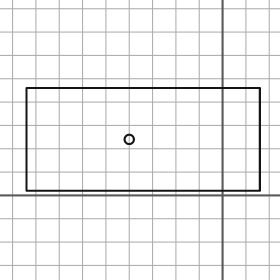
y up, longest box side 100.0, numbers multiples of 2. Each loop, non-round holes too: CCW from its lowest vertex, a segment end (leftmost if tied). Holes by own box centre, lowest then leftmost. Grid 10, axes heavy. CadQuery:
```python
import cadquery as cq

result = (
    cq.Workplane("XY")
    .moveTo(-84.0, 2.0)
    .lineTo(16.0, 2.0)
    .lineTo(16.0, 46.0)
    .lineTo(-84.0, 46.0)
    .close()
    .moveTo(-40.0, 24.0)
    .circle(2.0)
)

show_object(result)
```